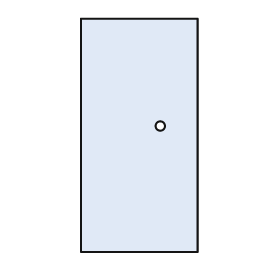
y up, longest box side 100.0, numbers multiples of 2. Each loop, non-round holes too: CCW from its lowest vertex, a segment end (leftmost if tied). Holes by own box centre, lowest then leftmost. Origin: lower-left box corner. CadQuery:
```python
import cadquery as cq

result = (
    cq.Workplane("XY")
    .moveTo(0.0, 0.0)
    .lineTo(50.0, 0.0)
    .lineTo(50.0, 100.0)
    .lineTo(0.0, 100.0)
    .close()
    .moveTo(34.0, 54.0)
    .circle(2.0)
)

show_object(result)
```